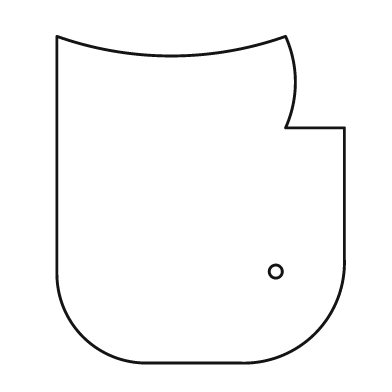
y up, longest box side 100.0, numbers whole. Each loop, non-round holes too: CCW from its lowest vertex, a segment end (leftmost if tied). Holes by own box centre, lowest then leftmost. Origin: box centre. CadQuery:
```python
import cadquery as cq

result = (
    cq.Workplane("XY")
    .moveTo(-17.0, -50.0)
    .lineTo(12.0, -50.0)
    .threePointArc((35.0, -41.0), (44.0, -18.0))
    .lineTo(44.0, 22.0)
    .lineTo(26.0, 22.0)
    .threePointArc((29.0, 36.0), (26.0, 50.0))
    .threePointArc((-9.0, 44.0), (-44.0, 50.0))
    .lineTo(-44.0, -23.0)
    .threePointArc((-36.0, -42.0), (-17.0, -50.0))
    .close()
    .moveTo(23.0, -22.0)
    .circle(2.0)
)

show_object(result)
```